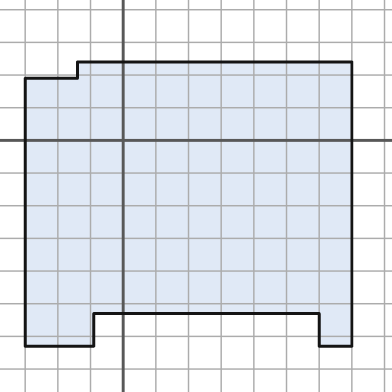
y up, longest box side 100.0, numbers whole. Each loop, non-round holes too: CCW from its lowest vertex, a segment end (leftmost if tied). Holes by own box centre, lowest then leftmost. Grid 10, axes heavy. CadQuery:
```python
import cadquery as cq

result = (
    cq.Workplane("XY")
    .moveTo(-30.0, -63.0)
    .lineTo(-9.0, -63.0)
    .lineTo(-9.0, -53.0)
    .lineTo(60.0, -53.0)
    .lineTo(60.0, -63.0)
    .lineTo(70.0, -63.0)
    .lineTo(70.0, 24.0)
    .lineTo(-14.0, 24.0)
    .lineTo(-14.0, 19.0)
    .lineTo(-30.0, 19.0)
    .close()
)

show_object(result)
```